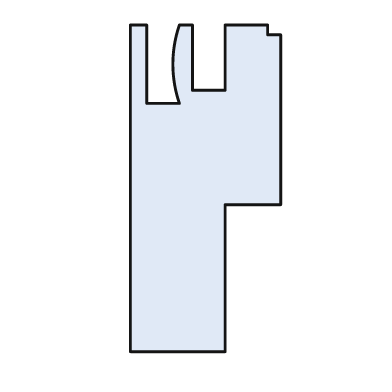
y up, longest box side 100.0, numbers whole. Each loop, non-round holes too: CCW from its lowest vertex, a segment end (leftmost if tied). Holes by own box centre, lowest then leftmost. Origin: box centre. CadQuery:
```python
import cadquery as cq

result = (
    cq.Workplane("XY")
    .moveTo(-23.0, -50.0)
    .lineTo(6.0, -50.0)
    .lineTo(6.0, -5.0)
    .lineTo(23.0, -5.0)
    .lineTo(23.0, 47.0)
    .lineTo(19.0, 47.0)
    .lineTo(19.0, 50.0)
    .lineTo(6.0, 50.0)
    .lineTo(6.0, 30.0)
    .lineTo(-4.0, 30.0)
    .lineTo(-4.0, 50.0)
    .lineTo(-8.0, 50.0)
    .threePointArc((-10.0, 38.0), (-8.0, 26.0))
    .lineTo(-18.0, 26.0)
    .lineTo(-18.0, 50.0)
    .lineTo(-23.0, 50.0)
    .close()
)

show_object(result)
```